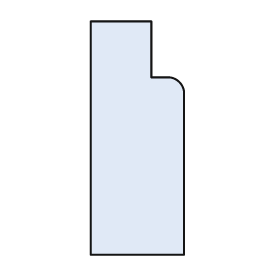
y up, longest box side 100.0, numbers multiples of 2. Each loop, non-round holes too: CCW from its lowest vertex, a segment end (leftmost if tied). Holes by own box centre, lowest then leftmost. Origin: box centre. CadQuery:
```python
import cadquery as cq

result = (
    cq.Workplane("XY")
    .moveTo(-20.0, -50.0)
    .lineTo(20.0, -50.0)
    .lineTo(20.0, 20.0)
    .threePointArc((18.0, 24.0), (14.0, 26.0))
    .lineTo(6.0, 26.0)
    .lineTo(6.0, 50.0)
    .lineTo(-20.0, 50.0)
    .close()
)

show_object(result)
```